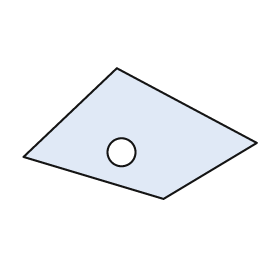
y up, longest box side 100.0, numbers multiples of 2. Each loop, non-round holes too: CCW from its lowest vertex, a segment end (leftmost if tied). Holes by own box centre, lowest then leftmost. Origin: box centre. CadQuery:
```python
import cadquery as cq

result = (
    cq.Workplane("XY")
    .moveTo(10.0, -28.0)
    .lineTo(50.0, -4.0)
    .lineTo(-10.0, 28.0)
    .lineTo(-50.0, -10.0)
    .close()
    .moveTo(-8.0, -8.0)
    .circle(6.0)
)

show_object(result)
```